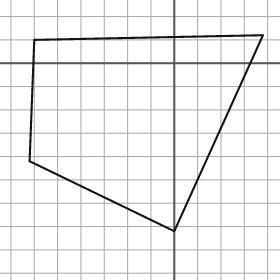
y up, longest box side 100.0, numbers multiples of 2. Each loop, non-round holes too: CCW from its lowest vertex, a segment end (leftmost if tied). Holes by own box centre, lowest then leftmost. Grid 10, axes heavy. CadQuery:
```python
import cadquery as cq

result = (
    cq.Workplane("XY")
    .moveTo(0.0, -72.0)
    .lineTo(38.0, 12.0)
    .lineTo(-60.0, 10.0)
    .lineTo(-62.0, -42.0)
    .close()
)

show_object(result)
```